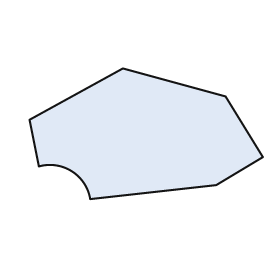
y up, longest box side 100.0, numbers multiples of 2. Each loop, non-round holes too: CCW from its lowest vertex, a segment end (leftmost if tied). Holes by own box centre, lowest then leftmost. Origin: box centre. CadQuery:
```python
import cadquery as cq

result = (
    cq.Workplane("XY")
    .moveTo(-24.0, -28.0)
    .lineTo(30.0, -22.0)
    .lineTo(50.0, -10.0)
    .lineTo(34.0, 16.0)
    .lineTo(-10.0, 28.0)
    .lineTo(-50.0, 6.0)
    .lineTo(-46.0, -14.0)
    .threePointArc((-32.0, -16.0), (-24.0, -28.0))
    .close()
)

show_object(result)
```